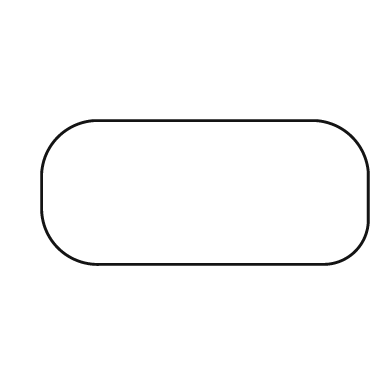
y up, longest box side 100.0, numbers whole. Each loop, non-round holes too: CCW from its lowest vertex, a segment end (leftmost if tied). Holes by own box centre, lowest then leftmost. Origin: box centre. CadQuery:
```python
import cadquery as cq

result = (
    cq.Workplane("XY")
    .moveTo(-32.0, -22.0)
    .lineTo(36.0, -22.0)
    .threePointArc((46.0, -18.0), (50.0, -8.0))
    .lineTo(50.0, 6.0)
    .threePointArc((45.0, 17.0), (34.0, 22.0))
    .lineTo(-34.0, 22.0)
    .threePointArc((-45.0, 17.0), (-50.0, 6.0))
    .lineTo(-50.0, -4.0)
    .threePointArc((-45.0, -17.0), (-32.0, -22.0))
    .close()
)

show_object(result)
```